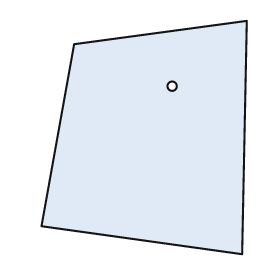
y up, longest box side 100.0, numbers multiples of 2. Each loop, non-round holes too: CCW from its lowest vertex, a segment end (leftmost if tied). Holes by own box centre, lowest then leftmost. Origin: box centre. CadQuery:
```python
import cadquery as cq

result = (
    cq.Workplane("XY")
    .moveTo(42.0, -50.0)
    .lineTo(44.0, 50.0)
    .lineTo(-30.0, 40.0)
    .lineTo(-44.0, -38.0)
    .close()
    .moveTo(12.0, 22.0)
    .circle(2.0)
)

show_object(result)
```